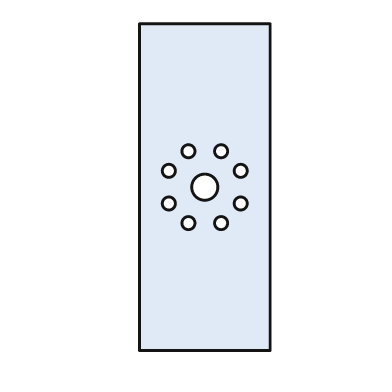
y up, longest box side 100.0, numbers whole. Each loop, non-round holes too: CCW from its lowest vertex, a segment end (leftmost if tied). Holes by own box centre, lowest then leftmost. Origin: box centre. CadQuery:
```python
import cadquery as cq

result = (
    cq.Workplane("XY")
    .moveTo(-20.0, -50.0)
    .lineTo(20.0, -50.0)
    .lineTo(20.0, 50.0)
    .lineTo(-20.0, 50.0)
    .close()
    .moveTo(-5.0, -11.0)
    .circle(2.0)
    .moveTo(5.0, -11.0)
    .circle(2.0)
    .moveTo(-11.0, -5.0)
    .circle(2.0)
    .moveTo(11.0, -5.0)
    .circle(2.0)
    .moveTo(0.0, 0.0)
    .circle(4.0)
    .moveTo(-11.0, 5.0)
    .circle(2.0)
    .moveTo(11.0, 5.0)
    .circle(2.0)
    .moveTo(-5.0, 11.0)
    .circle(2.0)
    .moveTo(5.0, 11.0)
    .circle(2.0)
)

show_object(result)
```